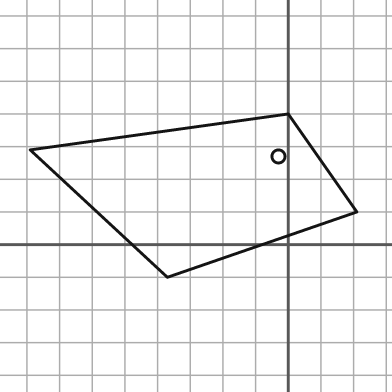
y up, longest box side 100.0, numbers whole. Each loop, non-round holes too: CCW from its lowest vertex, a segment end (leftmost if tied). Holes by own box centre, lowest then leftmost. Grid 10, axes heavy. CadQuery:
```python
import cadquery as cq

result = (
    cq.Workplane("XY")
    .moveTo(-37.0, -10.0)
    .lineTo(21.0, 10.0)
    .lineTo(0.0, 40.0)
    .lineTo(-79.0, 29.0)
    .close()
    .moveTo(-3.0, 27.0)
    .circle(2.0)
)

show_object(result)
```